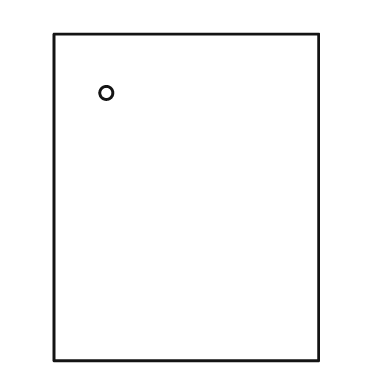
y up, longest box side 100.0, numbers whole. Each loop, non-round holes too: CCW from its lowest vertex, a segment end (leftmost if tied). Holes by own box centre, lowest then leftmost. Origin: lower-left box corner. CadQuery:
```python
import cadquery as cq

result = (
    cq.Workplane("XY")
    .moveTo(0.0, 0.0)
    .lineTo(81.0, 0.0)
    .lineTo(81.0, 100.0)
    .lineTo(0.0, 100.0)
    .close()
    .moveTo(16.0, 82.0)
    .circle(2.0)
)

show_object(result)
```